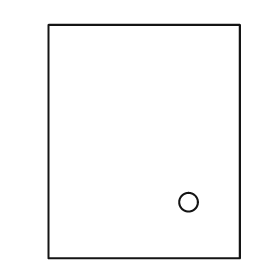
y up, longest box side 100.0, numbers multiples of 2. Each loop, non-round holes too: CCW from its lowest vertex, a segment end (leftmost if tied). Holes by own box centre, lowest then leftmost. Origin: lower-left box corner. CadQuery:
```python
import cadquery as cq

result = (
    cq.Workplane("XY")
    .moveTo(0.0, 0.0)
    .lineTo(82.0, 0.0)
    .lineTo(82.0, 100.0)
    .lineTo(0.0, 100.0)
    .close()
    .moveTo(60.0, 24.0)
    .circle(4.0)
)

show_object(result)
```